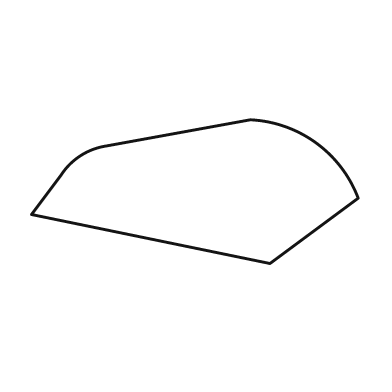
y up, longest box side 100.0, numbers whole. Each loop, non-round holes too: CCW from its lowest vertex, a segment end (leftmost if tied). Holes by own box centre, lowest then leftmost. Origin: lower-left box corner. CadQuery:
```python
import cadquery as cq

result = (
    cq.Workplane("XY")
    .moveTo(73.0, 0.0)
    .lineTo(100.0, 20.0)
    .threePointArc((87.0, 37.0), (67.0, 44.0))
    .lineTo(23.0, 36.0)
    .threePointArc((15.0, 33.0), (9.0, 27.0))
    .lineTo(0.0, 15.0)
    .close()
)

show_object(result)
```